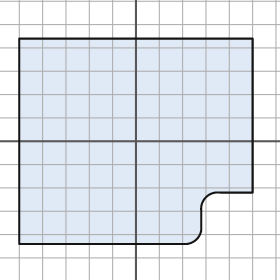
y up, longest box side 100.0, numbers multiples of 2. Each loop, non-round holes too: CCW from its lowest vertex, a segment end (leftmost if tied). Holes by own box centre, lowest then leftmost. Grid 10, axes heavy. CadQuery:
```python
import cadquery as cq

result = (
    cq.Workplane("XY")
    .moveTo(-50.0, -44.0)
    .lineTo(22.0, -44.0)
    .threePointArc((26.0, -42.0), (28.0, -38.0))
    .lineTo(28.0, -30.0)
    .threePointArc((30.0, -24.0), (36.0, -22.0))
    .lineTo(50.0, -22.0)
    .lineTo(50.0, 44.0)
    .lineTo(-50.0, 44.0)
    .close()
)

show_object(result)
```